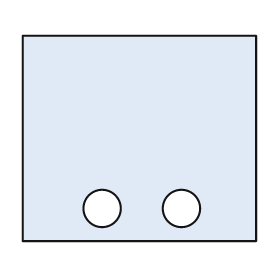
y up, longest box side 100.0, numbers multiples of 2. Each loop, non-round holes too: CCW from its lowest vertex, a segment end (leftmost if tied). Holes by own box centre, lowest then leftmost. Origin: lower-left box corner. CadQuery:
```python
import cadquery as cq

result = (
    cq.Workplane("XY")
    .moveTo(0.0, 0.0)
    .lineTo(100.0, 0.0)
    .lineTo(100.0, 88.0)
    .lineTo(0.0, 88.0)
    .close()
    .moveTo(34.0, 14.0)
    .circle(8.0)
    .moveTo(68.0, 14.0)
    .circle(8.0)
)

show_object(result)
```